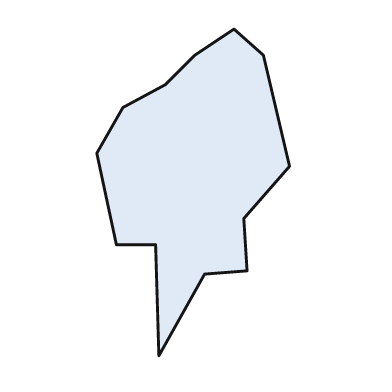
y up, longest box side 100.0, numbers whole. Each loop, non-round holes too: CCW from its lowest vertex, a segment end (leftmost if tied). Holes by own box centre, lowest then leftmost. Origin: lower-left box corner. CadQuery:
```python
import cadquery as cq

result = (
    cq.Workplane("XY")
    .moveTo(19.0, 0.0)
    .lineTo(33.0, 25.0)
    .lineTo(46.0, 26.0)
    .lineTo(45.0, 42.0)
    .lineTo(59.0, 58.0)
    .lineTo(51.0, 92.0)
    .lineTo(42.0, 100.0)
    .lineTo(30.0, 92.0)
    .lineTo(21.0, 83.0)
    .lineTo(8.0, 76.0)
    .lineTo(0.0, 62.0)
    .lineTo(6.0, 34.0)
    .lineTo(18.0, 34.0)
    .close()
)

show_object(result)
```